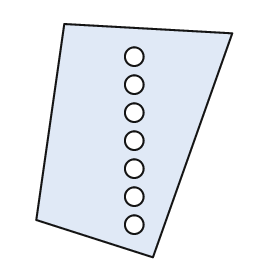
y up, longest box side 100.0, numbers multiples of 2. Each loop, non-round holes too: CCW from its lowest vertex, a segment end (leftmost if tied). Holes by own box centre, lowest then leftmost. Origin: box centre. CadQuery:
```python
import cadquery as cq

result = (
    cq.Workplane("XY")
    .moveTo(8.0, -50.0)
    .lineTo(42.0, 46.0)
    .lineTo(-30.0, 50.0)
    .lineTo(-42.0, -34.0)
    .close()
    .moveTo(0.0, -36.0)
    .circle(4.0)
    .moveTo(0.0, -24.0)
    .circle(4.0)
    .moveTo(0.0, -12.0)
    .circle(4.0)
    .moveTo(0.0, 0.0)
    .circle(4.0)
    .moveTo(0.0, 12.0)
    .circle(4.0)
    .moveTo(0.0, 24.0)
    .circle(4.0)
    .moveTo(0.0, 36.0)
    .circle(4.0)
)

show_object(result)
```